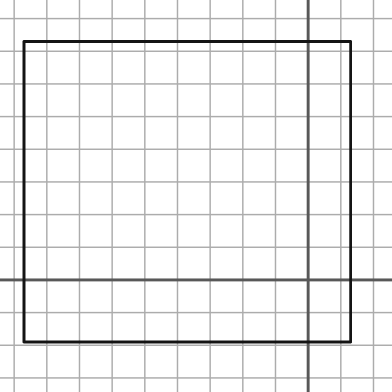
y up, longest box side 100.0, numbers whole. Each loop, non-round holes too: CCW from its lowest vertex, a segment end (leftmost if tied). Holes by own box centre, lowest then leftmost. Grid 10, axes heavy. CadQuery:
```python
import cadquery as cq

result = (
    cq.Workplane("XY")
    .moveTo(-87.0, -19.0)
    .lineTo(13.0, -19.0)
    .lineTo(13.0, 73.0)
    .lineTo(-87.0, 73.0)
    .close()
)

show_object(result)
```